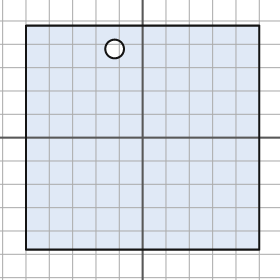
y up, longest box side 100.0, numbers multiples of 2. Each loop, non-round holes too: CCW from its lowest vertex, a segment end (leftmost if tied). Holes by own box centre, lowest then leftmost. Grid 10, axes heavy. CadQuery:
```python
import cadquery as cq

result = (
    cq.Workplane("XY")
    .moveTo(-50.0, -48.0)
    .lineTo(50.0, -48.0)
    .lineTo(50.0, 48.0)
    .lineTo(-50.0, 48.0)
    .close()
    .moveTo(-12.0, 38.0)
    .circle(4.0)
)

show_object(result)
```